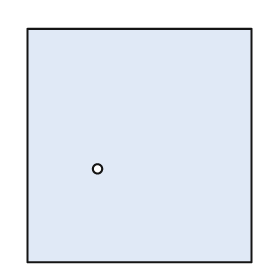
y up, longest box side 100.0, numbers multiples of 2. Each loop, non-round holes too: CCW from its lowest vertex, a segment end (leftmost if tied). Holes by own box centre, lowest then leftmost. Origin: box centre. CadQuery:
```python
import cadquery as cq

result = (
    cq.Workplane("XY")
    .moveTo(-48.0, -50.0)
    .lineTo(48.0, -50.0)
    .lineTo(48.0, 50.0)
    .lineTo(-48.0, 50.0)
    .close()
    .moveTo(-18.0, -10.0)
    .circle(2.0)
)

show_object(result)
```